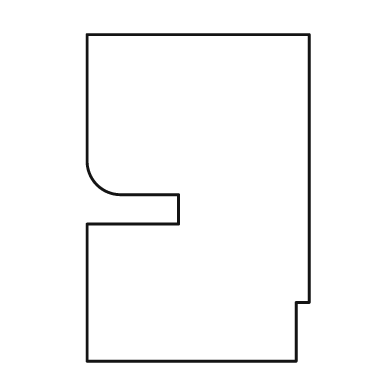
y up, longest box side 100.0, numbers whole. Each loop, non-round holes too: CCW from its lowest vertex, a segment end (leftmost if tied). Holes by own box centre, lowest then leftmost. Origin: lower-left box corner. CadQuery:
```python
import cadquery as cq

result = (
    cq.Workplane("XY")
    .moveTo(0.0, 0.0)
    .lineTo(64.0, 0.0)
    .lineTo(64.0, 18.0)
    .lineTo(68.0, 18.0)
    .lineTo(68.0, 100.0)
    .lineTo(0.0, 100.0)
    .lineTo(0.0, 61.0)
    .threePointArc((3.0, 54.0), (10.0, 51.0))
    .lineTo(28.0, 51.0)
    .lineTo(28.0, 42.0)
    .lineTo(0.0, 42.0)
    .close()
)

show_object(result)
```